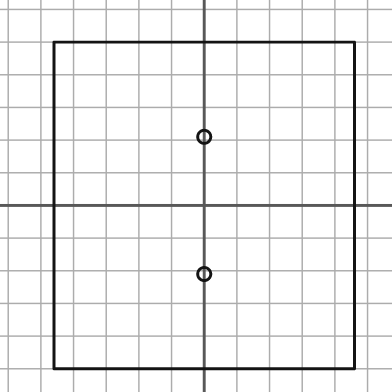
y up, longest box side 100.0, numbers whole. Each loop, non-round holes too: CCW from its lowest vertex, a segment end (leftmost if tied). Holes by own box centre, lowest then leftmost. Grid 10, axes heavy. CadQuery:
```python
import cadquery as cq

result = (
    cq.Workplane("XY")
    .moveTo(-46.0, -50.0)
    .lineTo(46.0, -50.0)
    .lineTo(46.0, 50.0)
    .lineTo(-46.0, 50.0)
    .close()
    .moveTo(0.0, -21.0)
    .circle(2.0)
    .moveTo(0.0, 21.0)
    .circle(2.0)
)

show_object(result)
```